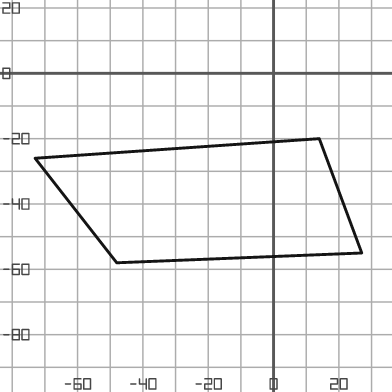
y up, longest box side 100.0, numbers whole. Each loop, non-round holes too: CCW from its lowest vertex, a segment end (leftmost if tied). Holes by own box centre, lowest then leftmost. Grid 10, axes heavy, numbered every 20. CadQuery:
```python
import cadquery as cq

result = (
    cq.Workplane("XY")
    .moveTo(-48.0, -58.0)
    .lineTo(27.0, -55.0)
    .lineTo(14.0, -20.0)
    .lineTo(-73.0, -26.0)
    .close()
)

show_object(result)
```